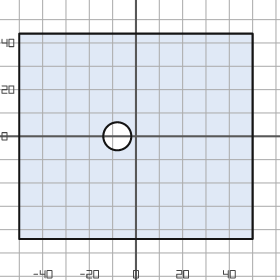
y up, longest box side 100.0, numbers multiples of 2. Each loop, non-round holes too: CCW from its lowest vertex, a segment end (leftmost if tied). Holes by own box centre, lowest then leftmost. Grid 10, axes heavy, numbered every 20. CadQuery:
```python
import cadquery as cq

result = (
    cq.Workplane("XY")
    .moveTo(-50.0, -44.0)
    .lineTo(50.0, -44.0)
    .lineTo(50.0, 44.0)
    .lineTo(-50.0, 44.0)
    .close()
    .moveTo(-8.0, 0.0)
    .circle(6.0)
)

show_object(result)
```